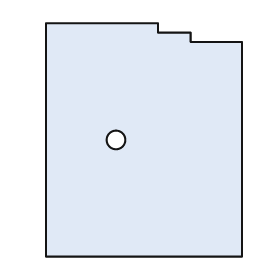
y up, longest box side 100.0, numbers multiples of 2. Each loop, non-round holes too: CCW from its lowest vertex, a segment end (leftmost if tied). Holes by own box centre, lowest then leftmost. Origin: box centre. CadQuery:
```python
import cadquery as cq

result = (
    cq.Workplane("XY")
    .moveTo(-42.0, -50.0)
    .lineTo(42.0, -50.0)
    .lineTo(42.0, 42.0)
    .lineTo(20.0, 42.0)
    .lineTo(20.0, 46.0)
    .lineTo(6.0, 46.0)
    .lineTo(6.0, 50.0)
    .lineTo(-42.0, 50.0)
    .close()
    .moveTo(-12.0, 0.0)
    .circle(4.0)
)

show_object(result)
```